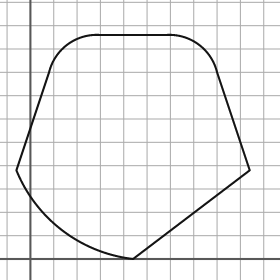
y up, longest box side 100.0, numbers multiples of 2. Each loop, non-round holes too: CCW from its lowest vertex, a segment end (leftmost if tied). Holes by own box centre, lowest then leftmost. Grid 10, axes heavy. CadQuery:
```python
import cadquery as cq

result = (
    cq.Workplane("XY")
    .moveTo(44.0, 0.0)
    .lineTo(94.0, 38.0)
    .lineTo(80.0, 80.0)
    .threePointArc((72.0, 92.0), (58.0, 96.0))
    .lineTo(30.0, 96.0)
    .threePointArc((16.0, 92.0), (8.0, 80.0))
    .lineTo(-6.0, 38.0)
    .threePointArc((14.0, 12.0), (44.0, 0.0))
    .close()
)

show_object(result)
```